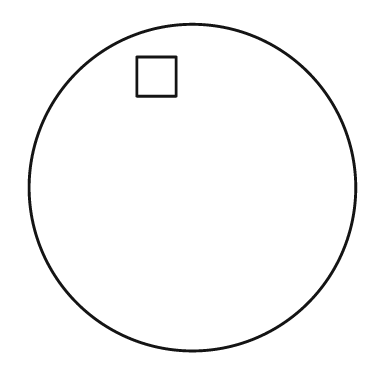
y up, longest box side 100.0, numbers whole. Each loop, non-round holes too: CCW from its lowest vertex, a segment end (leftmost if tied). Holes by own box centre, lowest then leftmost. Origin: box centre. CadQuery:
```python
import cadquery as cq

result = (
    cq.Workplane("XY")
    .moveTo(0.0, 0.0)
    .circle(50.0)
    .moveTo(-17.0, 28.0)
    .lineTo(-5.0, 28.0)
    .lineTo(-5.0, 40.0)
    .lineTo(-17.0, 40.0)
    .close()
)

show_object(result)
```